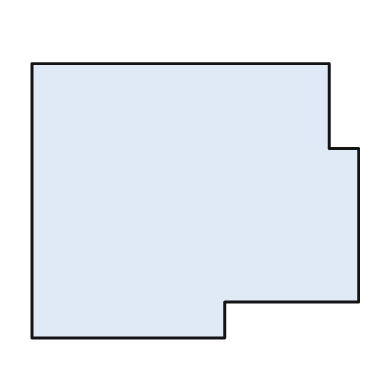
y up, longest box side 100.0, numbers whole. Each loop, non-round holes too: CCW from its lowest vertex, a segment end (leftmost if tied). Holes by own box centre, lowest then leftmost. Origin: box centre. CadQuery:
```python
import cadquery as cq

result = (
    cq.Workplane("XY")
    .moveTo(-50.0, -42.0)
    .lineTo(9.0, -42.0)
    .lineTo(9.0, -31.0)
    .lineTo(50.0, -31.0)
    .lineTo(50.0, 16.0)
    .lineTo(41.0, 16.0)
    .lineTo(41.0, 42.0)
    .lineTo(-50.0, 42.0)
    .close()
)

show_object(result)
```